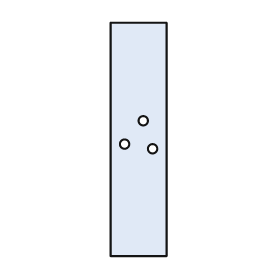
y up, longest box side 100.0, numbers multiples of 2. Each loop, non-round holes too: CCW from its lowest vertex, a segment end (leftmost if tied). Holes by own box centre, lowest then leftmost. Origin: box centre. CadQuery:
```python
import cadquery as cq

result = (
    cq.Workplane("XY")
    .moveTo(-12.0, -50.0)
    .lineTo(12.0, -50.0)
    .lineTo(12.0, 50.0)
    .lineTo(-12.0, 50.0)
    .close()
    .moveTo(6.0, -4.0)
    .circle(2.0)
    .moveTo(-6.0, -2.0)
    .circle(2.0)
    .moveTo(2.0, 8.0)
    .circle(2.0)
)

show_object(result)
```